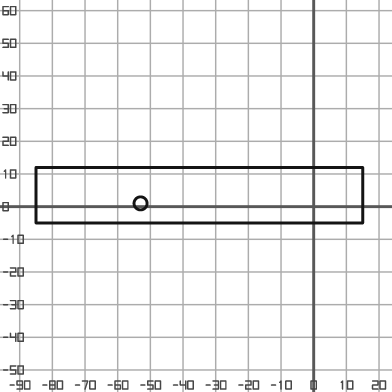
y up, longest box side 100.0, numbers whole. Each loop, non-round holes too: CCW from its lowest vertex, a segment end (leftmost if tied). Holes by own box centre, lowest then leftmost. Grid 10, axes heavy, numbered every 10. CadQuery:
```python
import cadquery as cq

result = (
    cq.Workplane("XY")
    .moveTo(-85.0, -5.0)
    .lineTo(15.0, -5.0)
    .lineTo(15.0, 12.0)
    .lineTo(-85.0, 12.0)
    .close()
    .moveTo(-53.0, 1.0)
    .circle(2.0)
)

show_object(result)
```